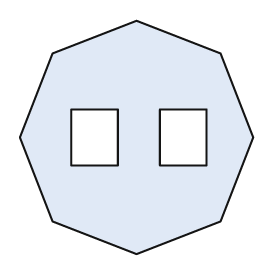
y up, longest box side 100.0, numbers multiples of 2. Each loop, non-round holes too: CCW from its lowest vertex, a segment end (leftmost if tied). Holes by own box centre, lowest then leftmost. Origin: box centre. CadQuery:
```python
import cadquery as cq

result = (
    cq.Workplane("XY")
    .moveTo(0.0, -50.0)
    .lineTo(36.0, -36.0)
    .lineTo(50.0, 0.0)
    .lineTo(36.0, 36.0)
    .lineTo(0.0, 50.0)
    .lineTo(-36.0, 36.0)
    .lineTo(-50.0, 0.0)
    .lineTo(-36.0, -36.0)
    .close()
    .moveTo(-28.0, -12.0)
    .lineTo(-8.0, -12.0)
    .lineTo(-8.0, 12.0)
    .lineTo(-28.0, 12.0)
    .close()
    .moveTo(10.0, -12.0)
    .lineTo(30.0, -12.0)
    .lineTo(30.0, 12.0)
    .lineTo(10.0, 12.0)
    .close()
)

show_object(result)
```